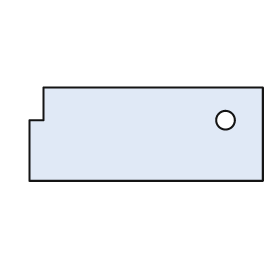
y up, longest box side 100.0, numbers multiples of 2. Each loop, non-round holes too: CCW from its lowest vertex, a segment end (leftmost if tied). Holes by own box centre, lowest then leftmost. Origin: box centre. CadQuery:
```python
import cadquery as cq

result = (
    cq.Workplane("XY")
    .moveTo(-50.0, -20.0)
    .lineTo(50.0, -20.0)
    .lineTo(50.0, 20.0)
    .lineTo(-44.0, 20.0)
    .lineTo(-44.0, 6.0)
    .lineTo(-50.0, 6.0)
    .close()
    .moveTo(34.0, 6.0)
    .circle(4.0)
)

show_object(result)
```